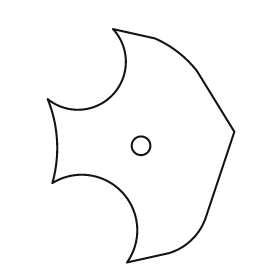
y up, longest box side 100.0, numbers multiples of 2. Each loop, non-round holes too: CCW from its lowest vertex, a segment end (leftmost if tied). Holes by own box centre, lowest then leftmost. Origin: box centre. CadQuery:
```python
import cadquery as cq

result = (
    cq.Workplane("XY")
    .moveTo(-6.0, -50.0)
    .lineTo(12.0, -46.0)
    .threePointArc((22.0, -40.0), (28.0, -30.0))
    .lineTo(40.0, 6.0)
    .lineTo(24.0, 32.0)
    .threePointArc((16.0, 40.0), (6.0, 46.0))
    .lineTo(-12.0, 50.0)
    .threePointArc((-12.0, 22.0), (-40.0, 20.0))
    .threePointArc((-36.0, 2.0), (-38.0, -16.0))
    .threePointArc((-8.0, -20.0), (-6.0, -50.0))
    .close()
    .moveTo(0.0, 0.0)
    .circle(4.0)
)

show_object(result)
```